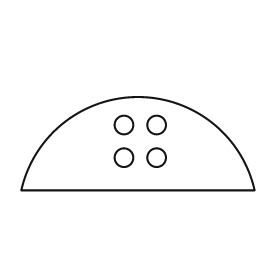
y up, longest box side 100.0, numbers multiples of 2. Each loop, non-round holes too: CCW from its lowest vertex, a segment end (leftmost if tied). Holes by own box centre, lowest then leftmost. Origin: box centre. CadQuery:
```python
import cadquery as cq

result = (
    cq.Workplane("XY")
    .moveTo(-50.0, -20.0)
    .lineTo(50.0, -20.0)
    .threePointArc((0.0, 20.0), (-50.0, -20.0))
    .close()
    .moveTo(-6.0, -6.0)
    .circle(4.0)
    .moveTo(8.0, -6.0)
    .circle(4.0)
    .moveTo(-6.0, 8.0)
    .circle(4.0)
    .moveTo(8.0, 8.0)
    .circle(4.0)
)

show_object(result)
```